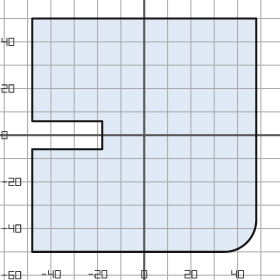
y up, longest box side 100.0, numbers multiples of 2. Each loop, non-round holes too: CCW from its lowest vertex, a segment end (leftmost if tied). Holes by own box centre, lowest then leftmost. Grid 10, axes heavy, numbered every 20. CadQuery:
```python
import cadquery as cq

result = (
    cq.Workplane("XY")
    .moveTo(-48.0, -50.0)
    .lineTo(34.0, -50.0)
    .threePointArc((44.0, -46.0), (48.0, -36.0))
    .lineTo(48.0, 50.0)
    .lineTo(-48.0, 50.0)
    .lineTo(-48.0, 6.0)
    .lineTo(-18.0, 6.0)
    .lineTo(-18.0, -6.0)
    .lineTo(-48.0, -6.0)
    .close()
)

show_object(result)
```